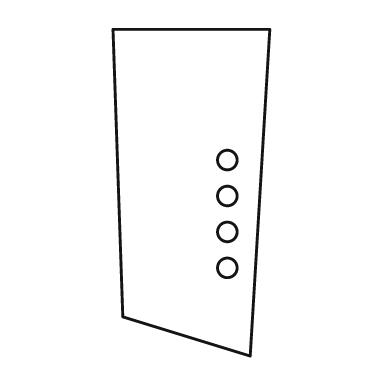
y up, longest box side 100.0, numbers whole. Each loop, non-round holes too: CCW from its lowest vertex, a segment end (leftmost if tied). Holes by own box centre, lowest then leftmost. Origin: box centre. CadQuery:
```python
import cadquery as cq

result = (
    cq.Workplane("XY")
    .moveTo(18.0, -50.0)
    .lineTo(24.0, 50.0)
    .lineTo(-24.0, 50.0)
    .lineTo(-21.0, -38.0)
    .close()
    .moveTo(11.0, -23.0)
    .circle(3.0)
    .moveTo(11.0, -12.0)
    .circle(3.0)
    .moveTo(11.0, -1.0)
    .circle(3.0)
    .moveTo(11.0, 10.0)
    .circle(3.0)
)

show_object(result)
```